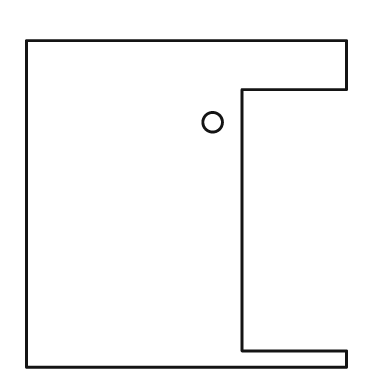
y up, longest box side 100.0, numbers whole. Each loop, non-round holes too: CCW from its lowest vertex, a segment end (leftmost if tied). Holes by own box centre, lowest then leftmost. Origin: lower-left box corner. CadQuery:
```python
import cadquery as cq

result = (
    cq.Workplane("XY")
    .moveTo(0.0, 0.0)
    .lineTo(98.0, 0.0)
    .lineTo(98.0, 5.0)
    .lineTo(66.0, 5.0)
    .lineTo(66.0, 85.0)
    .lineTo(98.0, 85.0)
    .lineTo(98.0, 100.0)
    .lineTo(0.0, 100.0)
    .close()
    .moveTo(57.0, 75.0)
    .circle(3.0)
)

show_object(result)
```